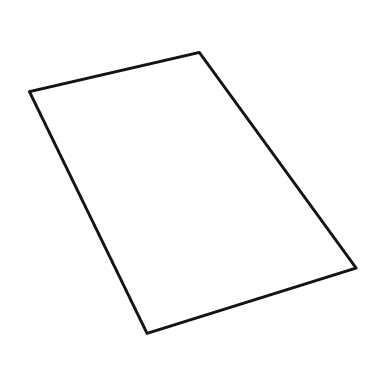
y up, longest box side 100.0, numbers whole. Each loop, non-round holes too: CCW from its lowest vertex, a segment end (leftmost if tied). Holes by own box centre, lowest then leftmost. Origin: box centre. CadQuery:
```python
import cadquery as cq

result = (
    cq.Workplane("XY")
    .moveTo(-14.0, -43.0)
    .lineTo(50.0, -23.0)
    .lineTo(2.0, 43.0)
    .lineTo(-50.0, 31.0)
    .close()
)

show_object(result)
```